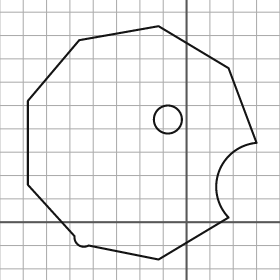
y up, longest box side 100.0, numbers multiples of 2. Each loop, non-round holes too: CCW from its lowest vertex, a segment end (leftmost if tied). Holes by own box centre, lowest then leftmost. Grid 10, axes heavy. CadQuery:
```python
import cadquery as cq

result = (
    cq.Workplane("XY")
    .moveTo(-12.0, -16.0)
    .lineTo(18.0, 2.0)
    .threePointArc((14.0, 22.0), (30.0, 34.0))
    .lineTo(18.0, 66.0)
    .lineTo(-12.0, 84.0)
    .lineTo(-46.0, 78.0)
    .lineTo(-68.0, 52.0)
    .lineTo(-68.0, 16.0)
    .lineTo(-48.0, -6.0)
    .threePointArc((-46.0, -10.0), (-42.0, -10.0))
    .close()
    .moveTo(-8.0, 44.0)
    .circle(6.0)
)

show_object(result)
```